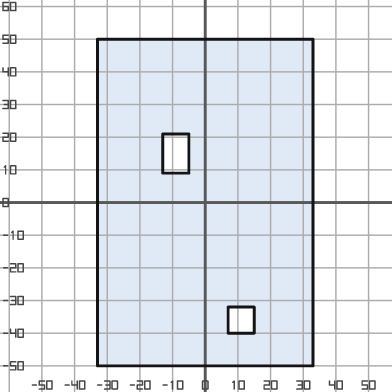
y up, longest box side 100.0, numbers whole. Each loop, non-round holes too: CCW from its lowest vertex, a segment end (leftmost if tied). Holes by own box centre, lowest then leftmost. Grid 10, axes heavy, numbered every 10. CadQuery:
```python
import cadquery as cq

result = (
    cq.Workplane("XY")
    .moveTo(-33.0, -50.0)
    .lineTo(33.0, -50.0)
    .lineTo(33.0, 50.0)
    .lineTo(-33.0, 50.0)
    .close()
    .moveTo(7.0, -40.0)
    .lineTo(15.0, -40.0)
    .lineTo(15.0, -32.0)
    .lineTo(7.0, -32.0)
    .close()
    .moveTo(-13.0, 9.0)
    .lineTo(-5.0, 9.0)
    .lineTo(-5.0, 21.0)
    .lineTo(-13.0, 21.0)
    .close()
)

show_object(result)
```